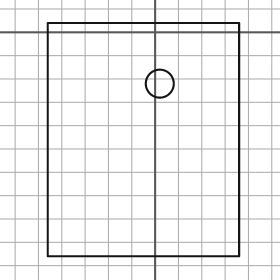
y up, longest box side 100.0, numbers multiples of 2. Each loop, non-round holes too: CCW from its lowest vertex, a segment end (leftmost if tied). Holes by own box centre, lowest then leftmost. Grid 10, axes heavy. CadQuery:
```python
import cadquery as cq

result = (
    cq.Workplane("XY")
    .moveTo(-46.0, -96.0)
    .lineTo(36.0, -96.0)
    .lineTo(36.0, 4.0)
    .lineTo(-46.0, 4.0)
    .close()
    .moveTo(2.0, -22.0)
    .circle(6.0)
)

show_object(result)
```